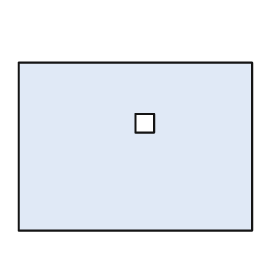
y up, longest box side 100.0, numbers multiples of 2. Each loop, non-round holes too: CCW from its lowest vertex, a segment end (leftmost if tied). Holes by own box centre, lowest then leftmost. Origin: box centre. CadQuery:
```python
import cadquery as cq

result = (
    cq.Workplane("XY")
    .moveTo(-50.0, -36.0)
    .lineTo(50.0, -36.0)
    .lineTo(50.0, 36.0)
    .lineTo(-50.0, 36.0)
    .close()
    .moveTo(0.0, 6.0)
    .lineTo(8.0, 6.0)
    .lineTo(8.0, 14.0)
    .lineTo(0.0, 14.0)
    .close()
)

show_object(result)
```